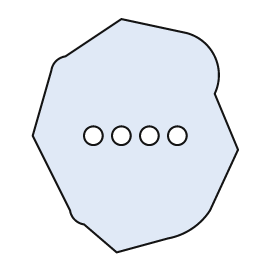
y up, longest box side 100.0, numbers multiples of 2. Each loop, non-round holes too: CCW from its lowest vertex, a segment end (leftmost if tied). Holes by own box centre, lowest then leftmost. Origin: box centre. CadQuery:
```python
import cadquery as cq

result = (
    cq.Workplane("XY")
    .moveTo(-8.0, -50.0)
    .lineTo(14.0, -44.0)
    .threePointArc((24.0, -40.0), (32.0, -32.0))
    .lineTo(44.0, -6.0)
    .lineTo(34.0, 18.0)
    .threePointArc((34.0, 34.0), (22.0, 44.0))
    .lineTo(-6.0, 50.0)
    .lineTo(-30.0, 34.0)
    .threePointArc((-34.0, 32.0), (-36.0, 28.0))
    .lineTo(-44.0, 0.0)
    .lineTo(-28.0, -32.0)
    .threePointArc((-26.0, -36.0), (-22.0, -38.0))
    .close()
    .moveTo(-18.0, 0.0)
    .circle(4.0)
    .moveTo(-6.0, 0.0)
    .circle(4.0)
    .moveTo(6.0, 0.0)
    .circle(4.0)
    .moveTo(18.0, 0.0)
    .circle(4.0)
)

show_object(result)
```